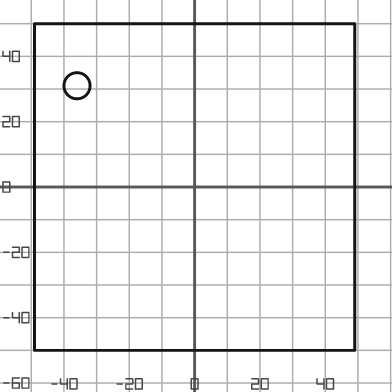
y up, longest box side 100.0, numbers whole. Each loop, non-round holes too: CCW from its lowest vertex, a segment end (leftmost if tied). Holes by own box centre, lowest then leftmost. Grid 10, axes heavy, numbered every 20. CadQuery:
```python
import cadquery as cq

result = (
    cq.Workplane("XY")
    .moveTo(-49.0, -50.0)
    .lineTo(49.0, -50.0)
    .lineTo(49.0, 50.0)
    .lineTo(-49.0, 50.0)
    .close()
    .moveTo(-36.0, 31.0)
    .circle(4.0)
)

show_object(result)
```